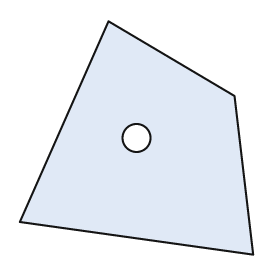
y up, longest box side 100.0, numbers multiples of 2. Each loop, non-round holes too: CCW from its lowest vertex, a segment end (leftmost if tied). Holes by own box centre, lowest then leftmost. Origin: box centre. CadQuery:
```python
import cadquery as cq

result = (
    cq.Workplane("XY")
    .moveTo(50.0, -50.0)
    .lineTo(42.0, 18.0)
    .lineTo(-12.0, 50.0)
    .lineTo(-50.0, -36.0)
    .close()
    .moveTo(0.0, 0.0)
    .circle(6.0)
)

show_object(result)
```